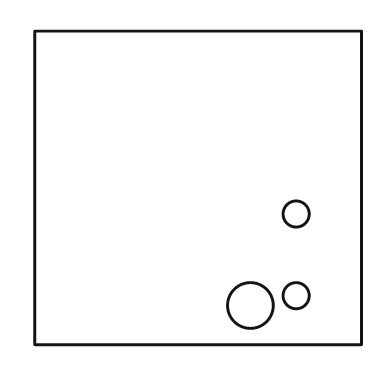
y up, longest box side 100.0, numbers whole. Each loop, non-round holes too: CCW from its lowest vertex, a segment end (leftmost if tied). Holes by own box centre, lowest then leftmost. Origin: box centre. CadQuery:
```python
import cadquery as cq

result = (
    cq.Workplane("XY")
    .moveTo(-50.0, -48.0)
    .lineTo(50.0, -48.0)
    .lineTo(50.0, 48.0)
    .lineTo(-50.0, 48.0)
    .close()
    .moveTo(16.0, -36.0)
    .circle(7.0)
    .moveTo(30.0, -33.0)
    .circle(4.0)
    .moveTo(30.0, -8.0)
    .circle(4.0)
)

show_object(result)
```